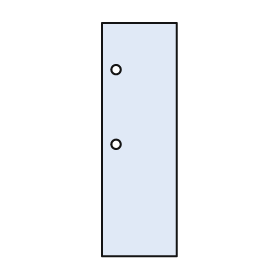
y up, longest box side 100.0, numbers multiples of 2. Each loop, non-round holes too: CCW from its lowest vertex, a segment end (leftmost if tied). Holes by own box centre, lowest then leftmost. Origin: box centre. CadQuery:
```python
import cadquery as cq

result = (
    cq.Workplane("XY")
    .moveTo(-16.0, -50.0)
    .lineTo(16.0, -50.0)
    .lineTo(16.0, 50.0)
    .lineTo(-16.0, 50.0)
    .close()
    .moveTo(-10.0, -2.0)
    .circle(2.0)
    .moveTo(-10.0, 30.0)
    .circle(2.0)
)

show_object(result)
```